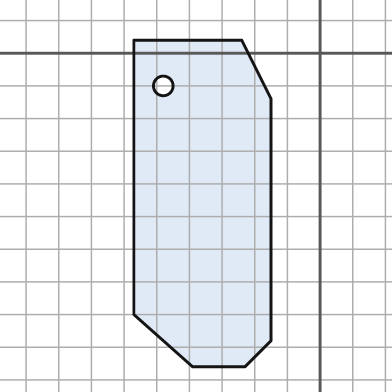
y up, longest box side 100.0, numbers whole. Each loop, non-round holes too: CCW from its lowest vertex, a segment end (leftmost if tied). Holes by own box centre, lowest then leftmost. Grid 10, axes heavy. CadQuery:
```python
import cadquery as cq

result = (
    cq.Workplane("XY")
    .moveTo(-39.0, -96.0)
    .lineTo(-23.0, -96.0)
    .lineTo(-15.0, -88.0)
    .lineTo(-15.0, -14.0)
    .lineTo(-24.0, 4.0)
    .lineTo(-57.0, 4.0)
    .lineTo(-57.0, -80.0)
    .close()
    .moveTo(-48.0, -10.0)
    .circle(3.0)
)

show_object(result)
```